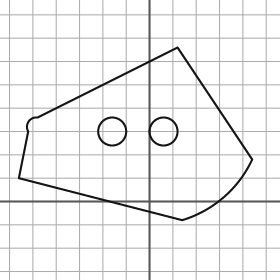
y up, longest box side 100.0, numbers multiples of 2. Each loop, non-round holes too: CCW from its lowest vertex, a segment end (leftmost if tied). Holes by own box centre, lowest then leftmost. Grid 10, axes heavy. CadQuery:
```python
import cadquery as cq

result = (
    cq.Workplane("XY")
    .moveTo(14.0, -8.0)
    .threePointArc((32.0, 2.0), (44.0, 18.0))
    .lineTo(12.0, 66.0)
    .lineTo(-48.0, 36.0)
    .threePointArc((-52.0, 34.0), (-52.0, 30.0))
    .lineTo(-56.0, 10.0)
    .close()
    .moveTo(-16.0, 30.0)
    .circle(6.0)
    .moveTo(6.0, 30.0)
    .circle(6.0)
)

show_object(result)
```